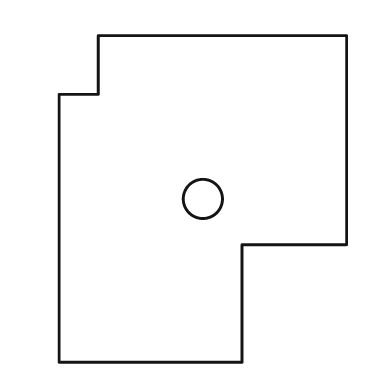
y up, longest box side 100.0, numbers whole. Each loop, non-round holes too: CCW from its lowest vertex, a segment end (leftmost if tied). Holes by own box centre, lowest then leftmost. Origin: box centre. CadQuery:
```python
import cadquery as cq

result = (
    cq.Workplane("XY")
    .moveTo(-44.0, -50.0)
    .lineTo(12.0, -50.0)
    .lineTo(12.0, -14.0)
    .lineTo(44.0, -14.0)
    .lineTo(44.0, 50.0)
    .lineTo(-32.0, 50.0)
    .lineTo(-32.0, 32.0)
    .lineTo(-44.0, 32.0)
    .close()
    .moveTo(0.0, 0.0)
    .circle(6.0)
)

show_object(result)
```